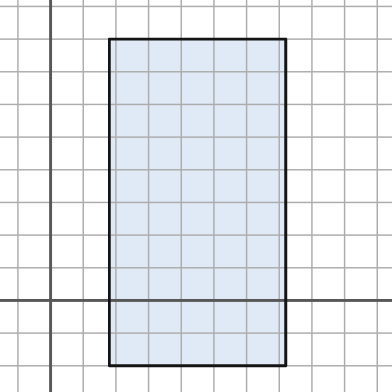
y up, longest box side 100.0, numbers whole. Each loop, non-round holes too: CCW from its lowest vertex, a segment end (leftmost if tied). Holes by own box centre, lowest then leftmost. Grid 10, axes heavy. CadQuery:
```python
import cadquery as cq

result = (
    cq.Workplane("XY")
    .moveTo(18.0, -20.0)
    .lineTo(72.0, -20.0)
    .lineTo(72.0, 80.0)
    .lineTo(18.0, 80.0)
    .close()
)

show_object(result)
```